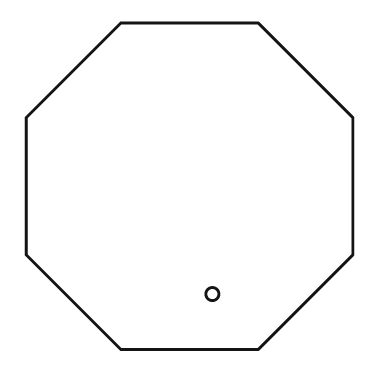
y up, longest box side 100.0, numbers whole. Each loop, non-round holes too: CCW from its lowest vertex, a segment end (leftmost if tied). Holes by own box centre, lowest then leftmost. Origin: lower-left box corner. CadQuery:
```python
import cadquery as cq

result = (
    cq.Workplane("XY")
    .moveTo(29.0, 0.0)
    .lineTo(71.0, 0.0)
    .lineTo(100.0, 29.0)
    .lineTo(100.0, 71.0)
    .lineTo(71.0, 100.0)
    .lineTo(29.0, 100.0)
    .lineTo(0.0, 71.0)
    .lineTo(0.0, 29.0)
    .close()
    .moveTo(57.0, 17.0)
    .circle(2.0)
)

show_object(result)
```